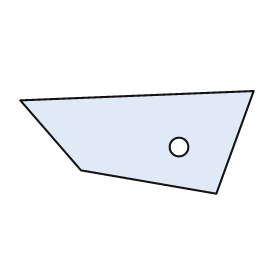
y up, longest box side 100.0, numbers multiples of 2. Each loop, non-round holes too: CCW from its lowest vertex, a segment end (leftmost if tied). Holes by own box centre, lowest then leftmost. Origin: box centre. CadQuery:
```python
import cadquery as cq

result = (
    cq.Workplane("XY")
    .moveTo(34.0, -22.0)
    .lineTo(50.0, 22.0)
    .lineTo(-50.0, 18.0)
    .lineTo(-24.0, -12.0)
    .close()
    .moveTo(18.0, -2.0)
    .circle(4.0)
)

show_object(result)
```